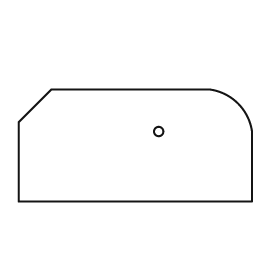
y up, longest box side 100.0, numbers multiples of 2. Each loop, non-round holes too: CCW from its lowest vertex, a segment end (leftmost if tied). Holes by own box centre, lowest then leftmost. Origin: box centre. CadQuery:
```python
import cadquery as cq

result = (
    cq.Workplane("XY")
    .moveTo(-50.0, -24.0)
    .lineTo(50.0, -24.0)
    .lineTo(50.0, 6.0)
    .threePointArc((44.0, 18.0), (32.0, 24.0))
    .lineTo(-36.0, 24.0)
    .lineTo(-50.0, 10.0)
    .close()
    .moveTo(10.0, 6.0)
    .circle(2.0)
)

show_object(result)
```